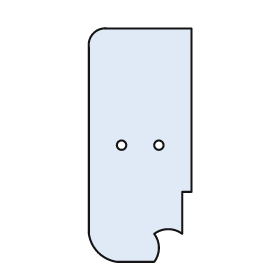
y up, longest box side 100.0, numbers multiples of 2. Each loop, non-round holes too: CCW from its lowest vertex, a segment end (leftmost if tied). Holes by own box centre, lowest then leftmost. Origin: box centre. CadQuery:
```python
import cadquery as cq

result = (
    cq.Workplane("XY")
    .moveTo(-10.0, -50.0)
    .lineTo(6.0, -50.0)
    .threePointArc((8.0, -44.0), (6.0, -38.0))
    .threePointArc((12.0, -36.0), (18.0, -38.0))
    .lineTo(18.0, -20.0)
    .lineTo(22.0, -20.0)
    .lineTo(22.0, 50.0)
    .lineTo(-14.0, 50.0)
    .threePointArc((-20.0, 48.0), (-22.0, 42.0))
    .lineTo(-22.0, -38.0)
    .threePointArc((-18.0, -46.0), (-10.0, -50.0))
    .close()
    .moveTo(-8.0, 0.0)
    .circle(2.0)
    .moveTo(8.0, 0.0)
    .circle(2.0)
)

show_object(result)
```